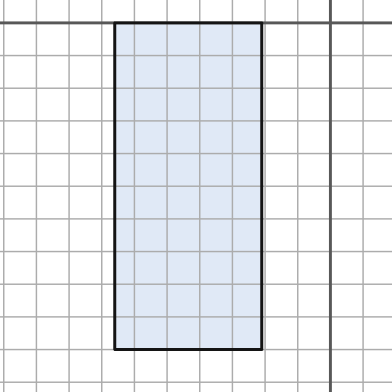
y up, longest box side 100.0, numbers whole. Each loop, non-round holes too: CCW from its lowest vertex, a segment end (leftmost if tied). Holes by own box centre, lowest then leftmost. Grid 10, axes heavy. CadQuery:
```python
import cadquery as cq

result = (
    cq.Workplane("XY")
    .moveTo(-66.0, -100.0)
    .lineTo(-21.0, -100.0)
    .lineTo(-21.0, 0.0)
    .lineTo(-66.0, 0.0)
    .close()
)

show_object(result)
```